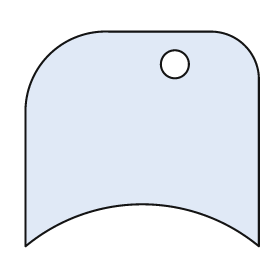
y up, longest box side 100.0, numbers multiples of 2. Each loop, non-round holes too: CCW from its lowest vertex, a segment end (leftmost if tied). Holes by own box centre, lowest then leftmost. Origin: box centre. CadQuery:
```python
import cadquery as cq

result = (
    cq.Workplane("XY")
    .moveTo(-50.0, -46.0)
    .threePointArc((0.0, -28.0), (50.0, -46.0))
    .lineTo(50.0, 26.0)
    .threePointArc((44.0, 40.0), (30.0, 46.0))
    .lineTo(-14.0, 46.0)
    .threePointArc((-40.0, 36.0), (-50.0, 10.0))
    .close()
    .moveTo(14.0, 32.0)
    .circle(6.0)
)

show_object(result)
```